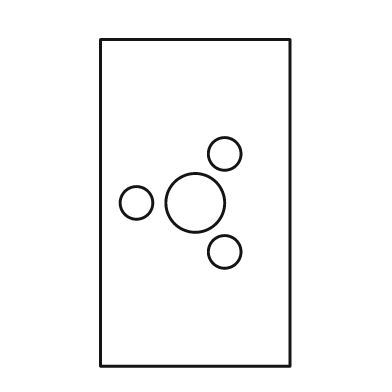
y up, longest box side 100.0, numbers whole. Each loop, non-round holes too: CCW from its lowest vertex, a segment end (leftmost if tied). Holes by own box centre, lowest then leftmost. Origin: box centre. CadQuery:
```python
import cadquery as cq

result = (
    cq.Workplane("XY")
    .moveTo(-29.0, -50.0)
    .lineTo(29.0, -50.0)
    .lineTo(29.0, 50.0)
    .lineTo(-29.0, 50.0)
    .close()
    .moveTo(9.0, -15.0)
    .circle(5.0)
    .moveTo(-18.0, 0.0)
    .circle(5.0)
    .moveTo(0.0, 0.0)
    .circle(9.0)
    .moveTo(9.0, 15.0)
    .circle(5.0)
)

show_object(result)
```